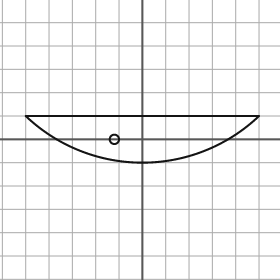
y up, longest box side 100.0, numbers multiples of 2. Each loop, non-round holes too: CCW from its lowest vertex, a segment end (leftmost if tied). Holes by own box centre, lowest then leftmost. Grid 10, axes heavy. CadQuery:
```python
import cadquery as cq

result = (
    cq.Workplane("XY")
    .moveTo(-50.0, 10.0)
    .threePointArc((0.0, -10.0), (50.0, 10.0))
    .close()
    .moveTo(-12.0, 0.0)
    .circle(2.0)
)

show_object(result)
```